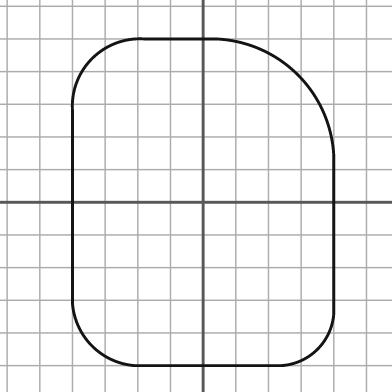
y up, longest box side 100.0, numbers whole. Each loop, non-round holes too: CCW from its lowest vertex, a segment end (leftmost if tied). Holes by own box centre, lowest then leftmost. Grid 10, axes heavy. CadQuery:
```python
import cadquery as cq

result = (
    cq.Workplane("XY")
    .moveTo(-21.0, -50.0)
    .lineTo(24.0, -50.0)
    .threePointArc((35.0, -45.0), (40.0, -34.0))
    .lineTo(40.0, 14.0)
    .threePointArc((29.0, 39.0), (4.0, 50.0))
    .lineTo(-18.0, 50.0)
    .threePointArc((-34.0, 44.0), (-40.0, 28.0))
    .lineTo(-40.0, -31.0)
    .threePointArc((-34.0, -44.0), (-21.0, -50.0))
    .close()
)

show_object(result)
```